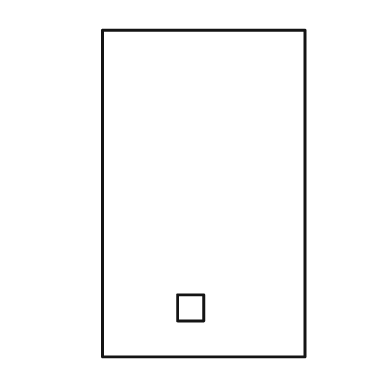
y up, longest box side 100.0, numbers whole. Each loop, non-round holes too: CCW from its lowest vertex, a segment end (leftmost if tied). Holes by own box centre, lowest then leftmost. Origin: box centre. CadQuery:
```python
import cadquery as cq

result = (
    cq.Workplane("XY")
    .moveTo(-31.0, -50.0)
    .lineTo(31.0, -50.0)
    .lineTo(31.0, 50.0)
    .lineTo(-31.0, 50.0)
    .close()
    .moveTo(-8.0, -39.0)
    .lineTo(0.0, -39.0)
    .lineTo(0.0, -31.0)
    .lineTo(-8.0, -31.0)
    .close()
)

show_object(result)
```